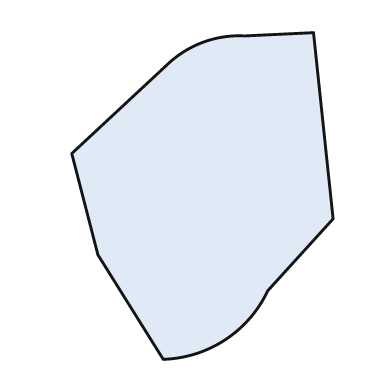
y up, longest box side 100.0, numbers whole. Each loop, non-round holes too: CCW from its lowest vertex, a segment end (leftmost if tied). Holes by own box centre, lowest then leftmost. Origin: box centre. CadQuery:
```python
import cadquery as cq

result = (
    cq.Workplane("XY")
    .moveTo(-12.0, -50.0)
    .threePointArc((7.0, -44.0), (20.0, -29.0))
    .lineTo(40.0, -7.0)
    .lineTo(34.0, 50.0)
    .lineTo(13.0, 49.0)
    .threePointArc((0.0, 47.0), (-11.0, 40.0))
    .lineTo(-40.0, 13.0)
    .lineTo(-32.0, -18.0)
    .close()
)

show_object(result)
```